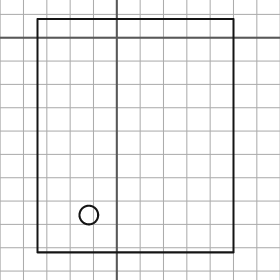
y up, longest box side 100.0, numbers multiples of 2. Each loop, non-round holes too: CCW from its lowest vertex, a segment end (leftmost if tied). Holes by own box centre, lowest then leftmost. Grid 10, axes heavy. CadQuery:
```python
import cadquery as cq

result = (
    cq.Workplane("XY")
    .moveTo(-34.0, -92.0)
    .lineTo(50.0, -92.0)
    .lineTo(50.0, 8.0)
    .lineTo(-34.0, 8.0)
    .close()
    .moveTo(-12.0, -76.0)
    .circle(4.0)
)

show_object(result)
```